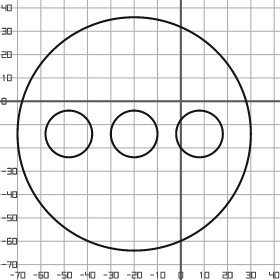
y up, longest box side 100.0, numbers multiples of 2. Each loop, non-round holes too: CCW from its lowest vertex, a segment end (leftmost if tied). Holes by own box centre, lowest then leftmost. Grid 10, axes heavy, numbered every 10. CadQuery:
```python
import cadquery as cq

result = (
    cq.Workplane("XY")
    .moveTo(-20.0, -14.0)
    .circle(50.0)
    .moveTo(-48.0, -14.0)
    .circle(10.0)
    .moveTo(-20.0, -14.0)
    .circle(10.0)
    .moveTo(8.0, -14.0)
    .circle(10.0)
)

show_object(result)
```